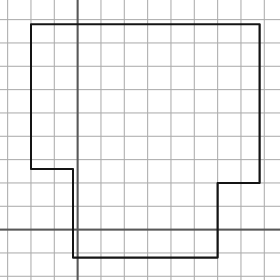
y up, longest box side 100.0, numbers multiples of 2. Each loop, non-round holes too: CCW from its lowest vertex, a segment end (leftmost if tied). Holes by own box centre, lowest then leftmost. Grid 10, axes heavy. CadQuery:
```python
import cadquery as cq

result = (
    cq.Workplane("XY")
    .moveTo(-2.0, -12.0)
    .lineTo(60.0, -12.0)
    .lineTo(60.0, 20.0)
    .lineTo(78.0, 20.0)
    .lineTo(78.0, 88.0)
    .lineTo(-20.0, 88.0)
    .lineTo(-20.0, 26.0)
    .lineTo(-2.0, 26.0)
    .close()
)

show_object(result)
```